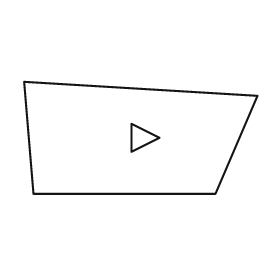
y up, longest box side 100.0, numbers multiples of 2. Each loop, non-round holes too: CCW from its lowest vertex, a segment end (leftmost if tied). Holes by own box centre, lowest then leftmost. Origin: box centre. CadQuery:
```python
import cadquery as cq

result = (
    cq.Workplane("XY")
    .moveTo(-46.0, -24.0)
    .lineTo(32.0, -24.0)
    .lineTo(50.0, 18.0)
    .lineTo(-50.0, 24.0)
    .close()
    .moveTo(-4.0, -6.0)
    .lineTo(8.0, 0.0)
    .lineTo(-4.0, 6.0)
    .close()
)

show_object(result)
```